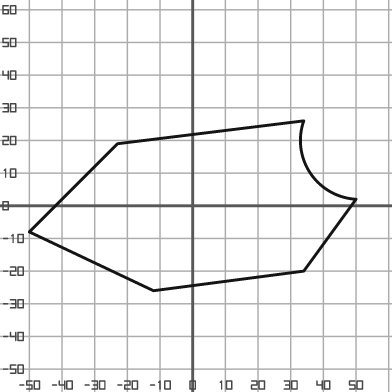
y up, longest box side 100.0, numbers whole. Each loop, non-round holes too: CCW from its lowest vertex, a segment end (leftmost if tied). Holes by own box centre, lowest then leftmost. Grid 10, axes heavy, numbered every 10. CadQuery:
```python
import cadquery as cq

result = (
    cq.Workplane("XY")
    .moveTo(-12.0, -26.0)
    .lineTo(34.0, -20.0)
    .lineTo(50.0, 2.0)
    .threePointArc((36.0, 10.0), (34.0, 26.0))
    .lineTo(-23.0, 19.0)
    .lineTo(-50.0, -8.0)
    .close()
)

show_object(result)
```